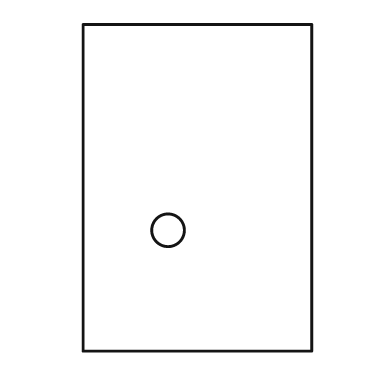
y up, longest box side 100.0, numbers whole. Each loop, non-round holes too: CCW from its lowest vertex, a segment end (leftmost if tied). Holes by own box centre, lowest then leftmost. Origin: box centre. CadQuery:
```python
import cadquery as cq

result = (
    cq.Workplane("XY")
    .moveTo(-35.0, -50.0)
    .lineTo(35.0, -50.0)
    .lineTo(35.0, 50.0)
    .lineTo(-35.0, 50.0)
    .close()
    .moveTo(-9.0, -13.0)
    .circle(5.0)
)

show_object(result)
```